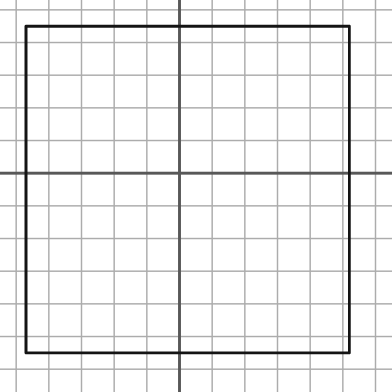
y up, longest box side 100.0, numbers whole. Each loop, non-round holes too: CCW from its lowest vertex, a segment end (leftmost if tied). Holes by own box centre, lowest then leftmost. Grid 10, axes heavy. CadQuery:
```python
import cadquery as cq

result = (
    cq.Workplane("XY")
    .moveTo(-47.0, -55.0)
    .lineTo(52.0, -55.0)
    .lineTo(52.0, 45.0)
    .lineTo(-47.0, 45.0)
    .close()
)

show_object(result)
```